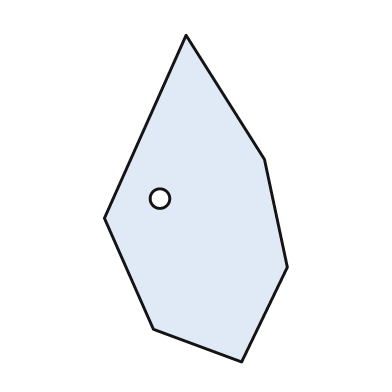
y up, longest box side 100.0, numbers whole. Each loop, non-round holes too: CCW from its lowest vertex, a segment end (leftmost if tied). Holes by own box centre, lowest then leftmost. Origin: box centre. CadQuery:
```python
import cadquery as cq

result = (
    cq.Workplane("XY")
    .moveTo(14.0, -50.0)
    .lineTo(28.0, -21.0)
    .lineTo(21.0, 12.0)
    .lineTo(-3.0, 50.0)
    .lineTo(-28.0, -6.0)
    .lineTo(-13.0, -40.0)
    .close()
    .moveTo(-11.0, 0.0)
    .circle(3.0)
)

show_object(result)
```